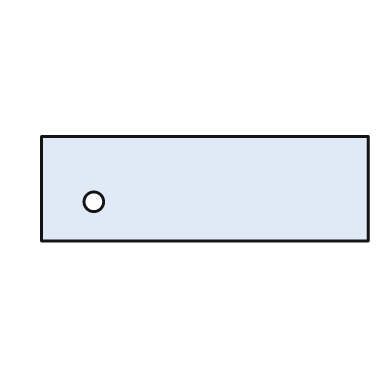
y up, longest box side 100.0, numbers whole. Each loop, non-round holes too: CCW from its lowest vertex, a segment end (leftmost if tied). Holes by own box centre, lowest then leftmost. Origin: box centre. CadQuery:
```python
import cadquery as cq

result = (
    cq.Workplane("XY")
    .moveTo(-50.0, -16.0)
    .lineTo(50.0, -16.0)
    .lineTo(50.0, 16.0)
    .lineTo(-50.0, 16.0)
    .close()
    .moveTo(-34.0, -4.0)
    .circle(3.0)
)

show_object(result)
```